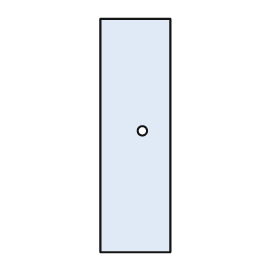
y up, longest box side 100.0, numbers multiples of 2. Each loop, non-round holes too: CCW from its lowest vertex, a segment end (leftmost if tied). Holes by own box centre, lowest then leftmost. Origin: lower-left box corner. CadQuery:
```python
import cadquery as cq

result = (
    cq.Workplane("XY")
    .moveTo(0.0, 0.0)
    .lineTo(30.0, 0.0)
    .lineTo(30.0, 100.0)
    .lineTo(0.0, 100.0)
    .close()
    .moveTo(18.0, 52.0)
    .circle(2.0)
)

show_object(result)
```